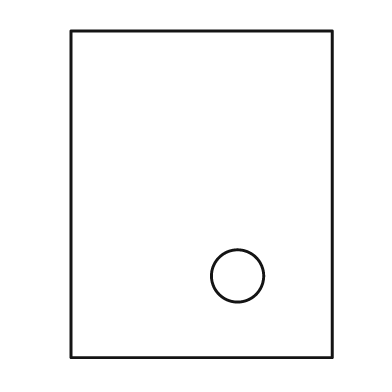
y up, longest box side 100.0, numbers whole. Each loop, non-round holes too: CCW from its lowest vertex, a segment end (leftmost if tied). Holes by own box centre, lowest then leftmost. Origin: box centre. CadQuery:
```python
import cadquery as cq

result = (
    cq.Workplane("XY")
    .moveTo(-40.0, -50.0)
    .lineTo(40.0, -50.0)
    .lineTo(40.0, 50.0)
    .lineTo(-40.0, 50.0)
    .close()
    .moveTo(11.0, -25.0)
    .circle(8.0)
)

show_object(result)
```